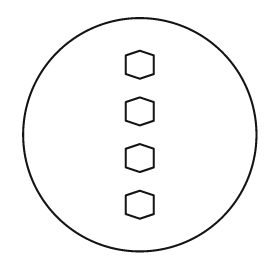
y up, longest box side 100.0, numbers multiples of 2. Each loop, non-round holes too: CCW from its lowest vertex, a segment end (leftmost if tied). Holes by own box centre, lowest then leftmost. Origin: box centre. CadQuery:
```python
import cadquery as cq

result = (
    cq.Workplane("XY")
    .moveTo(0.0, 0.0)
    .circle(50.0)
    .moveTo(0.0, -36.0)
    .lineTo(6.0, -34.0)
    .lineTo(6.0, -26.0)
    .lineTo(0.0, -24.0)
    .lineTo(-6.0, -26.0)
    .lineTo(-6.0, -34.0)
    .close()
    .moveTo(0.0, -16.0)
    .lineTo(6.0, -14.0)
    .lineTo(6.0, -6.0)
    .lineTo(0.0, -4.0)
    .lineTo(-6.0, -6.0)
    .lineTo(-6.0, -14.0)
    .close()
    .moveTo(0.0, 4.0)
    .lineTo(6.0, 6.0)
    .lineTo(6.0, 14.0)
    .lineTo(0.0, 16.0)
    .lineTo(-6.0, 14.0)
    .lineTo(-6.0, 6.0)
    .close()
    .moveTo(0.0, 24.0)
    .lineTo(6.0, 26.0)
    .lineTo(6.0, 34.0)
    .lineTo(0.0, 36.0)
    .lineTo(-6.0, 34.0)
    .lineTo(-6.0, 26.0)
    .close()
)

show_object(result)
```